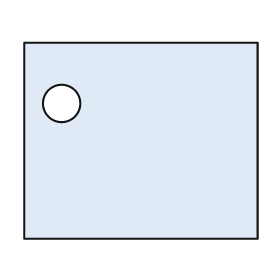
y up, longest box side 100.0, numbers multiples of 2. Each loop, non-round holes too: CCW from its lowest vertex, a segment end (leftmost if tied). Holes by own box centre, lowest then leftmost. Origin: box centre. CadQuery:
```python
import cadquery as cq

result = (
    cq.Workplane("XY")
    .moveTo(-50.0, -42.0)
    .lineTo(50.0, -42.0)
    .lineTo(50.0, 42.0)
    .lineTo(-50.0, 42.0)
    .close()
    .moveTo(-34.0, 16.0)
    .circle(8.0)
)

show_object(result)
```